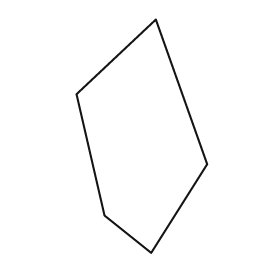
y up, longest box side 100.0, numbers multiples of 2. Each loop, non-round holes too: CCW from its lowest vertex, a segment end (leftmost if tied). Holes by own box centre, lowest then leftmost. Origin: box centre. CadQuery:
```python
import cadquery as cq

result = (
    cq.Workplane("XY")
    .moveTo(4.0, -50.0)
    .lineTo(28.0, -12.0)
    .lineTo(6.0, 50.0)
    .lineTo(-28.0, 18.0)
    .lineTo(-16.0, -34.0)
    .close()
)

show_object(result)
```